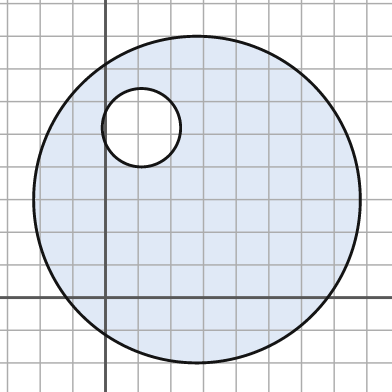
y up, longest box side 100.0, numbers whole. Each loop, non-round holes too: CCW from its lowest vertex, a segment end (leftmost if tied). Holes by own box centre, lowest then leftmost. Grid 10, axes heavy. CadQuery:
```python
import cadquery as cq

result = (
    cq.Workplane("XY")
    .moveTo(28.0, 30.0)
    .circle(50.0)
    .moveTo(11.0, 52.0)
    .circle(12.0)
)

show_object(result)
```